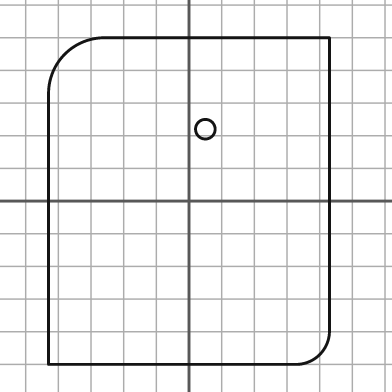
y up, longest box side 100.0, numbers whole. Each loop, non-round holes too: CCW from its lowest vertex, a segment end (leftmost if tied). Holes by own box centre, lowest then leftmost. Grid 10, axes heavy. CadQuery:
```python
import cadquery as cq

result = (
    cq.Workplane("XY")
    .moveTo(-43.0, -50.0)
    .lineTo(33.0, -50.0)
    .threePointArc((40.0, -47.0), (43.0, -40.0))
    .lineTo(43.0, 50.0)
    .lineTo(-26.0, 50.0)
    .threePointArc((-38.0, 45.0), (-43.0, 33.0))
    .close()
    .moveTo(5.0, 22.0)
    .circle(3.0)
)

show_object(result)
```